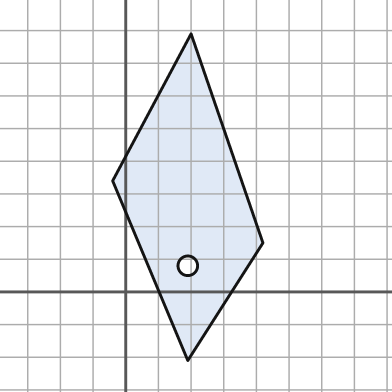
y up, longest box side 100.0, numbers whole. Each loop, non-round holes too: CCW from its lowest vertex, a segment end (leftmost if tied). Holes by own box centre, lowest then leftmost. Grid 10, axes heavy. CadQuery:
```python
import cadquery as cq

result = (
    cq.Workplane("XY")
    .moveTo(19.0, -21.0)
    .lineTo(42.0, 15.0)
    .lineTo(20.0, 79.0)
    .lineTo(-4.0, 34.0)
    .close()
    .moveTo(19.0, 8.0)
    .circle(3.0)
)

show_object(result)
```